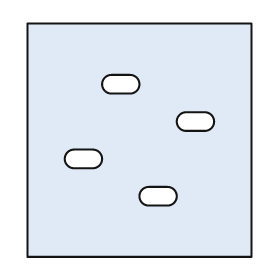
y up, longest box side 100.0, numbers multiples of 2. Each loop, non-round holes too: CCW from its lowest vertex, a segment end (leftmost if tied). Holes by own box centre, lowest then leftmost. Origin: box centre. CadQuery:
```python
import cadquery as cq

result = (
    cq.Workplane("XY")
    .moveTo(-48.0, -50.0)
    .lineTo(48.0, -50.0)
    .lineTo(48.0, 50.0)
    .lineTo(-48.0, 50.0)
    .close()
    .moveTo(4.0, -28.0)
    .lineTo(12.0, -28.0)
    .threePointArc((16.0, -24.0), (12.0, -20.0))
    .lineTo(4.0, -20.0)
    .threePointArc((0.0, -24.0), (4.0, -28.0))
    .close()
    .moveTo(-28.0, -12.0)
    .lineTo(-20.0, -12.0)
    .threePointArc((-16.0, -8.0), (-20.0, -4.0))
    .lineTo(-28.0, -4.0)
    .threePointArc((-32.0, -8.0), (-28.0, -12.0))
    .close()
    .moveTo(20.0, 4.0)
    .lineTo(28.0, 4.0)
    .threePointArc((32.0, 8.0), (28.0, 12.0))
    .lineTo(20.0, 12.0)
    .threePointArc((16.0, 8.0), (20.0, 4.0))
    .close()
    .moveTo(-12.0, 20.0)
    .lineTo(-4.0, 20.0)
    .threePointArc((0.0, 24.0), (-4.0, 28.0))
    .lineTo(-12.0, 28.0)
    .threePointArc((-16.0, 24.0), (-12.0, 20.0))
    .close()
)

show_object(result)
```